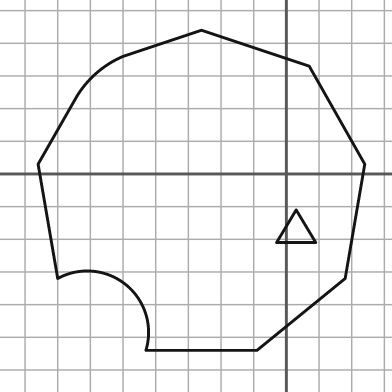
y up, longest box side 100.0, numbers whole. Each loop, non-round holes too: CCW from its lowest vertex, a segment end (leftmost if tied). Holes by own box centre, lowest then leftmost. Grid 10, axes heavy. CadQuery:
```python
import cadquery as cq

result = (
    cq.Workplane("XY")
    .moveTo(-43.0, -54.0)
    .lineTo(-9.0, -54.0)
    .lineTo(18.0, -32.0)
    .lineTo(24.0, 3.0)
    .lineTo(7.0, 33.0)
    .lineTo(-26.0, 44.0)
    .lineTo(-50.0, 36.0)
    .threePointArc((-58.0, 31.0), (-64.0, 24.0))
    .lineTo(-76.0, 3.0)
    .lineTo(-70.0, -32.0)
    .threePointArc((-49.0, -34.0), (-43.0, -54.0))
    .close()
    .moveTo(-3.0, -21.0)
    .lineTo(9.0, -21.0)
    .lineTo(3.0, -11.0)
    .close()
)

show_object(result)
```